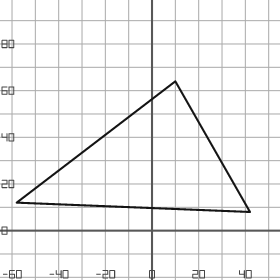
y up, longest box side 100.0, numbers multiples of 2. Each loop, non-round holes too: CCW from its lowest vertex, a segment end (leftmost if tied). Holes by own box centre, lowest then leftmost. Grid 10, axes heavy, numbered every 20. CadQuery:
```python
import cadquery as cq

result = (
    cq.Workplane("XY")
    .moveTo(42.0, 8.0)
    .lineTo(10.0, 64.0)
    .lineTo(-58.0, 12.0)
    .close()
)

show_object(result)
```